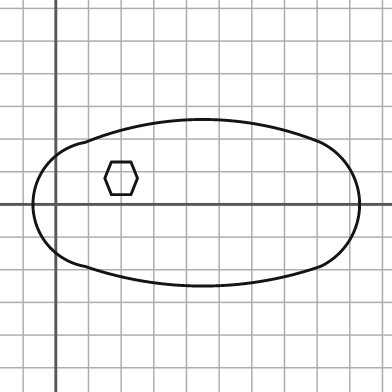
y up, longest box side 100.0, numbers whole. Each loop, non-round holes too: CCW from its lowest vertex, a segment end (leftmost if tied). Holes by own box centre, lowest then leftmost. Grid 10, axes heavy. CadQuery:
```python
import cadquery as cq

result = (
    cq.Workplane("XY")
    .moveTo(9.0, -19.0)
    .threePointArc((45.0, -25.0), (81.0, -19.0))
    .threePointArc((93.0, 0.0), (81.0, 19.0))
    .threePointArc((45.0, 26.0), (9.0, 19.0))
    .threePointArc((-7.0, 0.0), (9.0, -19.0))
    .close()
    .moveTo(17.0, 3.0)
    .lineTo(23.0, 3.0)
    .lineTo(25.0, 8.0)
    .lineTo(23.0, 13.0)
    .lineTo(17.0, 13.0)
    .lineTo(15.0, 8.0)
    .close()
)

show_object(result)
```